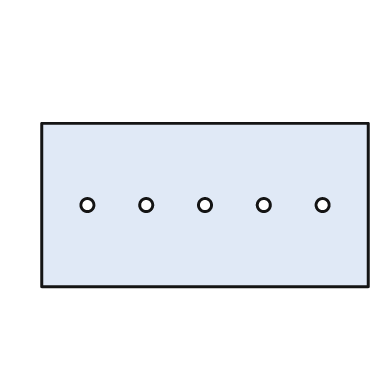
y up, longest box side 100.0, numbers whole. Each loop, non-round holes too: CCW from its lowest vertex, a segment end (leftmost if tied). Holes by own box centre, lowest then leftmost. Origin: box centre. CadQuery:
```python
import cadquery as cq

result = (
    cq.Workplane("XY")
    .moveTo(-50.0, -25.0)
    .lineTo(50.0, -25.0)
    .lineTo(50.0, 25.0)
    .lineTo(-50.0, 25.0)
    .close()
    .moveTo(-36.0, 0.0)
    .circle(2.0)
    .moveTo(-18.0, 0.0)
    .circle(2.0)
    .moveTo(0.0, 0.0)
    .circle(2.0)
    .moveTo(18.0, 0.0)
    .circle(2.0)
    .moveTo(36.0, 0.0)
    .circle(2.0)
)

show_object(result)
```